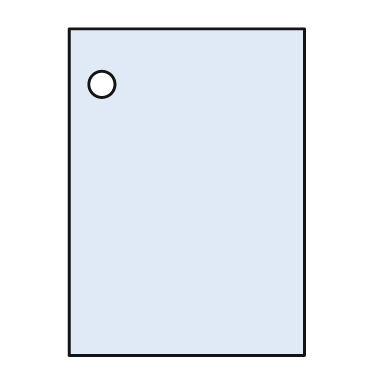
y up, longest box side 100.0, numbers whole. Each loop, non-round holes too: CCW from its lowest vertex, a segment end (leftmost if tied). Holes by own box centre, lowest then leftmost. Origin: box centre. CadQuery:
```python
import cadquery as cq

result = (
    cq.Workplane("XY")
    .moveTo(-36.0, -50.0)
    .lineTo(36.0, -50.0)
    .lineTo(36.0, 50.0)
    .lineTo(-36.0, 50.0)
    .close()
    .moveTo(-26.0, 33.0)
    .circle(4.0)
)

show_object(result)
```